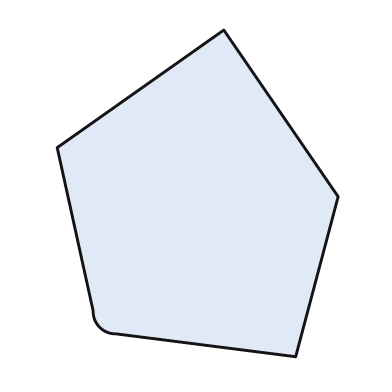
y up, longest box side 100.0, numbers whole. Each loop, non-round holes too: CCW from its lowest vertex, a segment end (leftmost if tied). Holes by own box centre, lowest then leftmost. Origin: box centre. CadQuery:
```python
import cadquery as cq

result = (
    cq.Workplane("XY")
    .moveTo(30.0, -50.0)
    .lineTo(43.0, -1.0)
    .lineTo(8.0, 50.0)
    .lineTo(-43.0, 14.0)
    .lineTo(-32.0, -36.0)
    .threePointArc((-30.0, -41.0), (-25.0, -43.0))
    .close()
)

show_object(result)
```